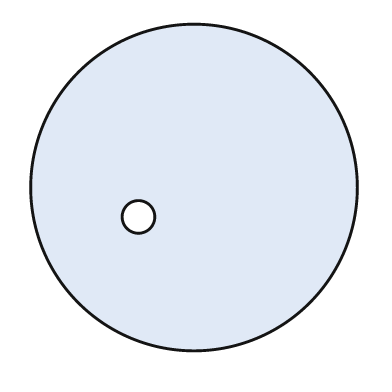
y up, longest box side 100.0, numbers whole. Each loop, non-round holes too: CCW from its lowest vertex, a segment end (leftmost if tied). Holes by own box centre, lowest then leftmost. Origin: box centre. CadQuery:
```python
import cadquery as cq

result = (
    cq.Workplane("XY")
    .moveTo(0.0, 0.0)
    .circle(50.0)
    .moveTo(-17.0, -9.0)
    .circle(5.0)
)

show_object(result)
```